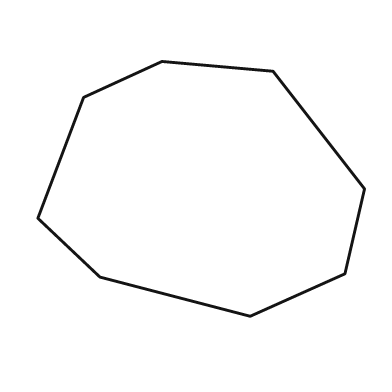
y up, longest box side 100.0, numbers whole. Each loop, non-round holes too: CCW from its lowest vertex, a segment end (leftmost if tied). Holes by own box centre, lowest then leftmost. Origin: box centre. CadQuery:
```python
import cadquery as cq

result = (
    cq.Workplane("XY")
    .moveTo(15.0, -39.0)
    .lineTo(44.0, -26.0)
    .lineTo(50.0, 0.0)
    .lineTo(22.0, 36.0)
    .lineTo(-12.0, 39.0)
    .lineTo(-36.0, 28.0)
    .lineTo(-50.0, -9.0)
    .lineTo(-31.0, -27.0)
    .close()
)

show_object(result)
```